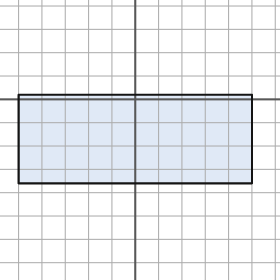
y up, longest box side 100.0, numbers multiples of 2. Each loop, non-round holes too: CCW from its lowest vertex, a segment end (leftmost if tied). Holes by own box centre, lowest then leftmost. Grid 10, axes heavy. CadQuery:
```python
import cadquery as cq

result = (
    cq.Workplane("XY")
    .moveTo(-50.0, -36.0)
    .lineTo(50.0, -36.0)
    .lineTo(50.0, 2.0)
    .lineTo(-50.0, 2.0)
    .close()
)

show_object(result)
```